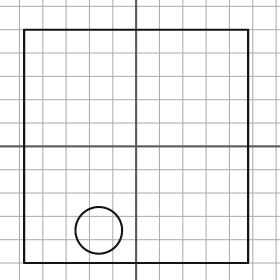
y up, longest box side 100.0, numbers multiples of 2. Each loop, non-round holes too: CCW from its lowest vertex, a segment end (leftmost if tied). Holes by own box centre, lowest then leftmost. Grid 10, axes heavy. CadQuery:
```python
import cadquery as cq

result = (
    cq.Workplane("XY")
    .moveTo(-48.0, -50.0)
    .lineTo(48.0, -50.0)
    .lineTo(48.0, 50.0)
    .lineTo(-48.0, 50.0)
    .close()
    .moveTo(-16.0, -36.0)
    .circle(10.0)
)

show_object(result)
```